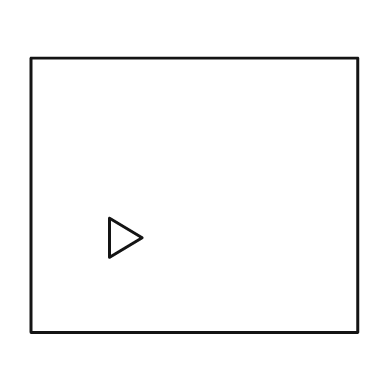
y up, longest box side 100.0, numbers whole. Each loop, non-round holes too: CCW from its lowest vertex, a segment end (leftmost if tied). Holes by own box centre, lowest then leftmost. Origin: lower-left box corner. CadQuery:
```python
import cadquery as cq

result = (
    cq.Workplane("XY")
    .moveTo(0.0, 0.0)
    .lineTo(100.0, 0.0)
    .lineTo(100.0, 84.0)
    .lineTo(0.0, 84.0)
    .close()
    .moveTo(24.0, 23.0)
    .lineTo(34.0, 29.0)
    .lineTo(24.0, 35.0)
    .close()
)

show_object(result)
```